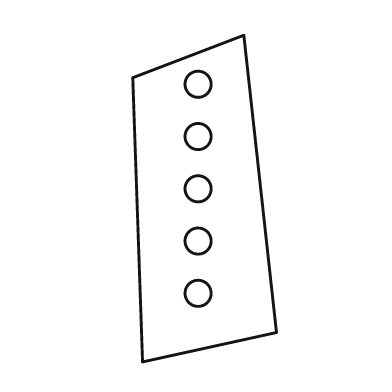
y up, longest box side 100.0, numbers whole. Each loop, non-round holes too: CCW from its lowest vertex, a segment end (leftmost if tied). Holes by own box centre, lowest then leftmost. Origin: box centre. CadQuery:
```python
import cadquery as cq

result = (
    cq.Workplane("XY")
    .moveTo(-19.0, -50.0)
    .lineTo(22.0, -41.0)
    .lineTo(12.0, 50.0)
    .lineTo(-22.0, 37.0)
    .close()
    .moveTo(-2.0, -29.0)
    .circle(4.0)
    .moveTo(-2.0, -13.0)
    .circle(4.0)
    .moveTo(-2.0, 3.0)
    .circle(4.0)
    .moveTo(-2.0, 19.0)
    .circle(4.0)
    .moveTo(-2.0, 35.0)
    .circle(4.0)
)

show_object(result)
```